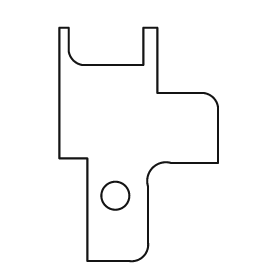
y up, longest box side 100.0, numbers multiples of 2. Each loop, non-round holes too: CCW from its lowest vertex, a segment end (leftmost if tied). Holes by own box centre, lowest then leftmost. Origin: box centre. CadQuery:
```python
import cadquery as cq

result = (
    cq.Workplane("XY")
    .moveTo(-22.0, -50.0)
    .lineTo(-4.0, -50.0)
    .threePointArc((2.0, -48.0), (4.0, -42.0))
    .lineTo(4.0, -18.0)
    .threePointArc((6.0, -10.0), (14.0, -8.0))
    .lineTo(34.0, -8.0)
    .lineTo(34.0, 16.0)
    .threePointArc((32.0, 20.0), (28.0, 22.0))
    .lineTo(8.0, 22.0)
    .lineTo(8.0, 50.0)
    .lineTo(2.0, 50.0)
    .lineTo(2.0, 34.0)
    .lineTo(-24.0, 34.0)
    .threePointArc((-28.0, 36.0), (-30.0, 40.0))
    .lineTo(-30.0, 50.0)
    .lineTo(-34.0, 50.0)
    .lineTo(-34.0, -6.0)
    .lineTo(-22.0, -6.0)
    .close()
    .moveTo(-10.0, -22.0)
    .circle(6.0)
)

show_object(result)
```